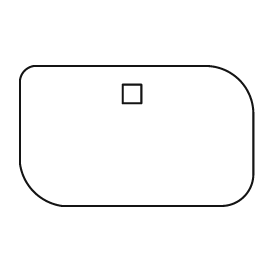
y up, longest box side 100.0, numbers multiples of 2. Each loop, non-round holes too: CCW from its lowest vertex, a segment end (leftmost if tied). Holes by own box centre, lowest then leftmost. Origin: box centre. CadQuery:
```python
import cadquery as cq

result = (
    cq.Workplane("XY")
    .moveTo(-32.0, -30.0)
    .lineTo(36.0, -30.0)
    .threePointArc((46.0, -26.0), (50.0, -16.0))
    .lineTo(50.0, 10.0)
    .threePointArc((44.0, 24.0), (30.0, 30.0))
    .lineTo(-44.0, 30.0)
    .threePointArc((-48.0, 28.0), (-50.0, 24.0))
    .lineTo(-50.0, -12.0)
    .threePointArc((-44.0, -24.0), (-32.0, -30.0))
    .close()
    .moveTo(-6.0, 14.0)
    .lineTo(2.0, 14.0)
    .lineTo(2.0, 22.0)
    .lineTo(-6.0, 22.0)
    .close()
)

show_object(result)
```